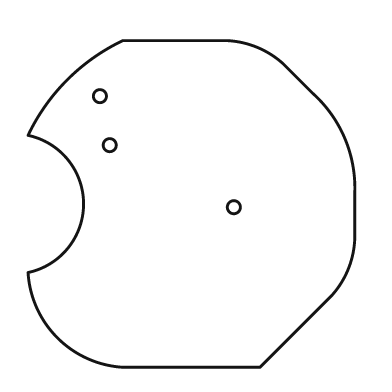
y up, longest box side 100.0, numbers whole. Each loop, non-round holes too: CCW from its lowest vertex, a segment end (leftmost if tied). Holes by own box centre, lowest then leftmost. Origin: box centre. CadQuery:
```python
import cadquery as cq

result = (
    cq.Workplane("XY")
    .moveTo(-21.0, -50.0)
    .lineTo(21.0, -50.0)
    .lineTo(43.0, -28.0)
    .threePointArc((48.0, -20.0), (50.0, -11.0))
    .lineTo(50.0, 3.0)
    .threePointArc((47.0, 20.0), (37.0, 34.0))
    .lineTo(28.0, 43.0)
    .threePointArc((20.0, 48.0), (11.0, 50.0))
    .lineTo(-21.0, 50.0)
    .threePointArc((-38.0, 38.0), (-50.0, 21.0))
    .threePointArc((-33.0, 0.0), (-50.0, -21.0))
    .threePointArc((-41.0, -41.0), (-21.0, -50.0))
    .close()
    .moveTo(13.0, -1.0)
    .circle(2.0)
    .moveTo(-25.0, 18.0)
    .circle(2.0)
    .moveTo(-28.0, 33.0)
    .circle(2.0)
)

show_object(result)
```